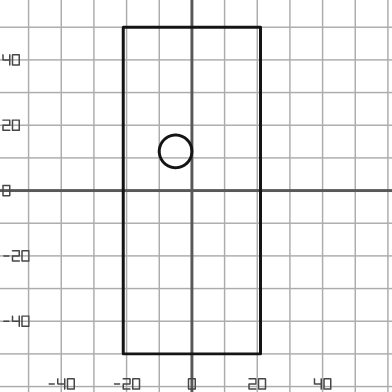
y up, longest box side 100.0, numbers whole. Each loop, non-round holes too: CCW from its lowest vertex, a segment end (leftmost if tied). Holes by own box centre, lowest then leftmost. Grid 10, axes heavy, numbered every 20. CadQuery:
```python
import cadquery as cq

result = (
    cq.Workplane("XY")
    .moveTo(-21.0, -50.0)
    .lineTo(21.0, -50.0)
    .lineTo(21.0, 50.0)
    .lineTo(-21.0, 50.0)
    .close()
    .moveTo(-5.0, 12.0)
    .circle(5.0)
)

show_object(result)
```